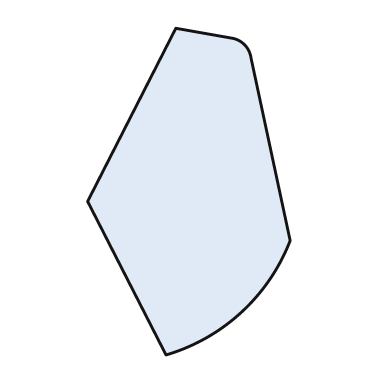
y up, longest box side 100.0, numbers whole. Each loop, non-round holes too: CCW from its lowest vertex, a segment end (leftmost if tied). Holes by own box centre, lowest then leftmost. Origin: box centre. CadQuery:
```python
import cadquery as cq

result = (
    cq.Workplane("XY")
    .moveTo(-7.0, -50.0)
    .threePointArc((16.0, -37.0), (31.0, -15.0))
    .lineTo(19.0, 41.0)
    .threePointArc((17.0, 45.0), (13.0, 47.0))
    .lineTo(-4.0, 50.0)
    .lineTo(-31.0, -3.0)
    .close()
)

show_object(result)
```